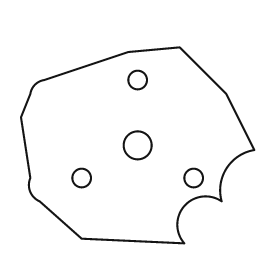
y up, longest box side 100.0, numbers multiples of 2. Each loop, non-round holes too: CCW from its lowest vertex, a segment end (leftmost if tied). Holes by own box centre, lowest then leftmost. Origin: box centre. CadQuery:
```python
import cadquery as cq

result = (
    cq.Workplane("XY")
    .moveTo(20.0, -42.0)
    .threePointArc((20.0, -26.0), (36.0, -24.0))
    .threePointArc((38.0, -10.0), (50.0, -2.0))
    .lineTo(38.0, 22.0)
    .lineTo(18.0, 42.0)
    .lineTo(-4.0, 40.0)
    .lineTo(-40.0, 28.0)
    .threePointArc((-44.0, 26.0), (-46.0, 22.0))
    .lineTo(-50.0, 12.0)
    .lineTo(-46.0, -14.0)
    .threePointArc((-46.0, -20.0), (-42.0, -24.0))
    .lineTo(-24.0, -40.0)
    .close()
    .moveTo(-24.0, -14.0)
    .circle(4.0)
    .moveTo(24.0, -14.0)
    .circle(4.0)
    .moveTo(0.0, 0.0)
    .circle(6.0)
    .moveTo(0.0, 28.0)
    .circle(4.0)
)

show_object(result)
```